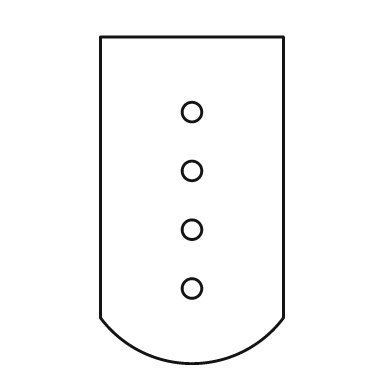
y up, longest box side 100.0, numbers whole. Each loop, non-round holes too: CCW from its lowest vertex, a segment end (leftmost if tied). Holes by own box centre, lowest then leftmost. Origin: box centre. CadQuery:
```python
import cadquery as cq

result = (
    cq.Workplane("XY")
    .moveTo(-28.0, -36.0)
    .threePointArc((0.0, -50.0), (28.0, -36.0))
    .lineTo(28.0, 50.0)
    .lineTo(-28.0, 50.0)
    .close()
    .moveTo(0.0, -27.0)
    .circle(3.0)
    .moveTo(0.0, -9.0)
    .circle(3.0)
    .moveTo(0.0, 9.0)
    .circle(3.0)
    .moveTo(0.0, 27.0)
    .circle(3.0)
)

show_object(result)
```